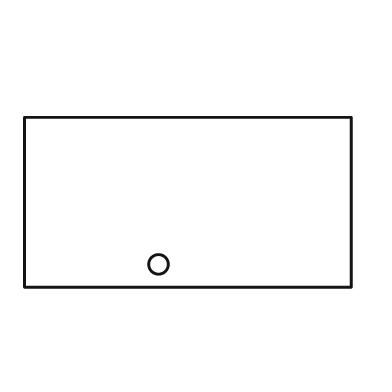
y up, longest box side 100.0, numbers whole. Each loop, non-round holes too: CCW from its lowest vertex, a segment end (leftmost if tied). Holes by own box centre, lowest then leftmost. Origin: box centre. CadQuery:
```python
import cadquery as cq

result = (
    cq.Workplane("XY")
    .moveTo(-50.0, -26.0)
    .lineTo(50.0, -26.0)
    .lineTo(50.0, 26.0)
    .lineTo(-50.0, 26.0)
    .close()
    .moveTo(-9.0, -19.0)
    .circle(3.0)
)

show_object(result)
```